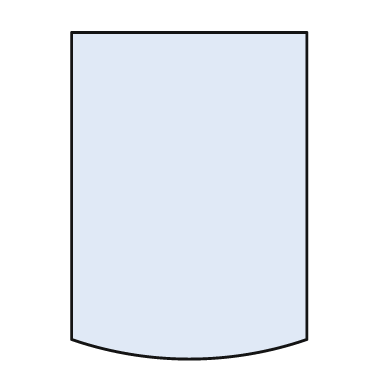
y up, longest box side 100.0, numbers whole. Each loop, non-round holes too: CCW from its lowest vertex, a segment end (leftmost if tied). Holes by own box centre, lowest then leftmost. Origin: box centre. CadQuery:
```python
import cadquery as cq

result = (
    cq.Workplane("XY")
    .moveTo(-36.0, -44.0)
    .threePointArc((0.0, -50.0), (36.0, -44.0))
    .lineTo(36.0, 50.0)
    .lineTo(-36.0, 50.0)
    .close()
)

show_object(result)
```